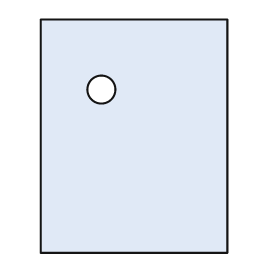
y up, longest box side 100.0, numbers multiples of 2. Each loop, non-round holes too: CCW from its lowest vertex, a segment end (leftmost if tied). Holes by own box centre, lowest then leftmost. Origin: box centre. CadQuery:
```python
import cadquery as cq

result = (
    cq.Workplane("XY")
    .moveTo(-40.0, -50.0)
    .lineTo(40.0, -50.0)
    .lineTo(40.0, 50.0)
    .lineTo(-40.0, 50.0)
    .close()
    .moveTo(-14.0, 20.0)
    .circle(6.0)
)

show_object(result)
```